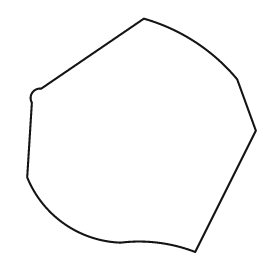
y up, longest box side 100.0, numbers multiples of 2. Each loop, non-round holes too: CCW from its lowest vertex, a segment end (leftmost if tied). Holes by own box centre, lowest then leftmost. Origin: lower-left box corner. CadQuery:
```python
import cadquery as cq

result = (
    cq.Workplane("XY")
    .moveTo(72.0, 0.0)
    .lineTo(98.0, 52.0)
    .lineTo(90.0, 74.0)
    .threePointArc((72.0, 90.0), (50.0, 100.0))
    .lineTo(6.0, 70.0)
    .threePointArc((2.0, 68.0), (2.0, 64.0))
    .lineTo(0.0, 32.0)
    .threePointArc((16.0, 12.0), (40.0, 4.0))
    .threePointArc((56.0, 4.0), (72.0, 0.0))
    .close()
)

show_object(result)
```